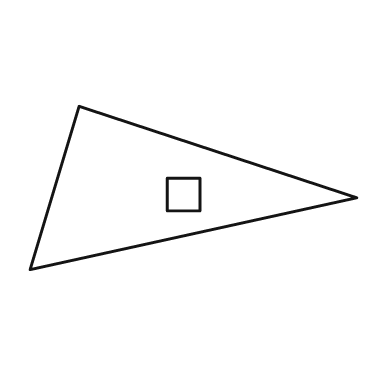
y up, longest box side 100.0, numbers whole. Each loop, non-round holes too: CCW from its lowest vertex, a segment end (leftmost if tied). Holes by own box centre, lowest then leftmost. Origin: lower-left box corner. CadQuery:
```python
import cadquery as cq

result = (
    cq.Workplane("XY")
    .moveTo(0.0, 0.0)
    .lineTo(100.0, 22.0)
    .lineTo(15.0, 50.0)
    .close()
    .moveTo(42.0, 18.0)
    .lineTo(52.0, 18.0)
    .lineTo(52.0, 28.0)
    .lineTo(42.0, 28.0)
    .close()
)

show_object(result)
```